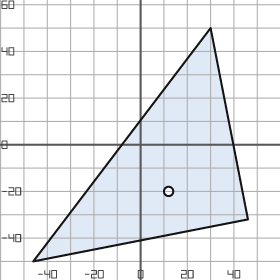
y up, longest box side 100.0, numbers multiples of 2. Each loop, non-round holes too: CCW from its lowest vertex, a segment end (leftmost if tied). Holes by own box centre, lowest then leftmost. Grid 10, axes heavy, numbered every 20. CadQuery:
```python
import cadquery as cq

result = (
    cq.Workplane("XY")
    .moveTo(-46.0, -50.0)
    .lineTo(46.0, -32.0)
    .lineTo(30.0, 50.0)
    .close()
    .moveTo(12.0, -20.0)
    .circle(2.0)
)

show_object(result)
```